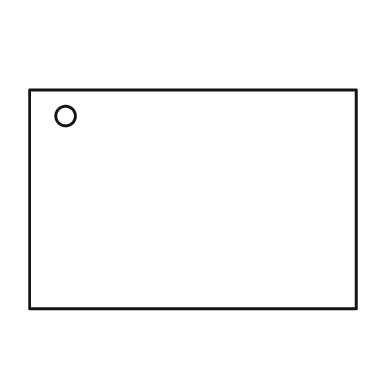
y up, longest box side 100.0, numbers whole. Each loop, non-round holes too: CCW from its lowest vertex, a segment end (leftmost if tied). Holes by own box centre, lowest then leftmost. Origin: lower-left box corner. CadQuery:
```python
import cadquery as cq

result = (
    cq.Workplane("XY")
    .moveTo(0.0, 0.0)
    .lineTo(100.0, 0.0)
    .lineTo(100.0, 67.0)
    .lineTo(0.0, 67.0)
    .close()
    .moveTo(11.0, 59.0)
    .circle(3.0)
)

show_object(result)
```